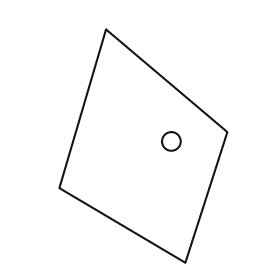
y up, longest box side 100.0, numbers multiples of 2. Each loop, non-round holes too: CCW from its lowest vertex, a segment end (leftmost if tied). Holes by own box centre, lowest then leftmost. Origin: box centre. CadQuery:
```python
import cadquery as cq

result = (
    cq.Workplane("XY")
    .moveTo(18.0, -50.0)
    .lineTo(36.0, 6.0)
    .lineTo(-16.0, 50.0)
    .lineTo(-36.0, -18.0)
    .close()
    .moveTo(12.0, 2.0)
    .circle(4.0)
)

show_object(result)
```